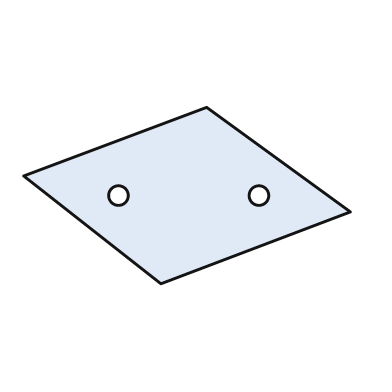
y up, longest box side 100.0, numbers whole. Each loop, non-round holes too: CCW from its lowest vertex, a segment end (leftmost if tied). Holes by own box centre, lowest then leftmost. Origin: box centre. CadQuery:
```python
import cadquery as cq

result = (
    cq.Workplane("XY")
    .moveTo(-8.0, -27.0)
    .lineTo(50.0, -5.0)
    .lineTo(6.0, 27.0)
    .lineTo(-50.0, 6.0)
    .close()
    .moveTo(-21.0, 0.0)
    .circle(3.0)
    .moveTo(22.0, 0.0)
    .circle(3.0)
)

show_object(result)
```